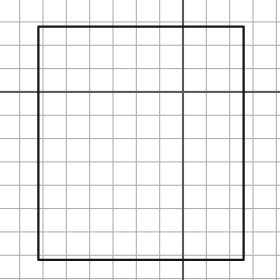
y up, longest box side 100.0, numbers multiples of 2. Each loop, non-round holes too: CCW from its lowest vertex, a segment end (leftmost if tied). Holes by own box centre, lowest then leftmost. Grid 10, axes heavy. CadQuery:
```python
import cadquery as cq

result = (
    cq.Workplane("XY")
    .moveTo(-62.0, -72.0)
    .lineTo(26.0, -72.0)
    .lineTo(26.0, 28.0)
    .lineTo(-62.0, 28.0)
    .close()
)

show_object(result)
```